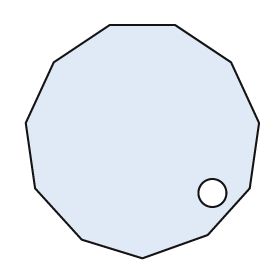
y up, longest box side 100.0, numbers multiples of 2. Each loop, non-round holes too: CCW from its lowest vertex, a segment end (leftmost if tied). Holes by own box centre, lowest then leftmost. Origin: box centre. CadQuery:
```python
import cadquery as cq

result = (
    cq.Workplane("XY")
    .moveTo(0.0, -50.0)
    .lineTo(28.0, -40.0)
    .lineTo(46.0, -20.0)
    .lineTo(50.0, 8.0)
    .lineTo(38.0, 34.0)
    .lineTo(14.0, 50.0)
    .lineTo(-14.0, 50.0)
    .lineTo(-38.0, 34.0)
    .lineTo(-50.0, 8.0)
    .lineTo(-46.0, -20.0)
    .lineTo(-26.0, -42.0)
    .close()
    .moveTo(30.0, -22.0)
    .circle(6.0)
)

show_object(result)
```